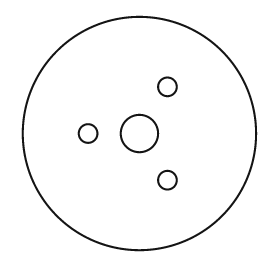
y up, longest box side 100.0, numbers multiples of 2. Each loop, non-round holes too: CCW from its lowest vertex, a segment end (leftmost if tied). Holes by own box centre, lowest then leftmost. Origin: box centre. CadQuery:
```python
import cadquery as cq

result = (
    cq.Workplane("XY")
    .moveTo(0.0, 0.0)
    .circle(50.0)
    .moveTo(12.0, -20.0)
    .circle(4.0)
    .moveTo(-22.0, 0.0)
    .circle(4.0)
    .moveTo(0.0, 0.0)
    .circle(8.0)
    .moveTo(12.0, 20.0)
    .circle(4.0)
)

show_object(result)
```